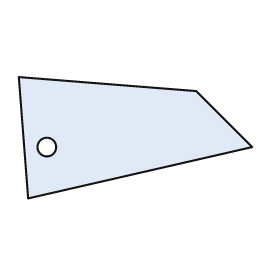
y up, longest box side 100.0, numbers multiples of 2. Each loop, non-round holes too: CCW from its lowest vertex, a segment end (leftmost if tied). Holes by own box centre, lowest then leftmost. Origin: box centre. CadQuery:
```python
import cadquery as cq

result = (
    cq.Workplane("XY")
    .moveTo(-46.0, -26.0)
    .lineTo(50.0, -4.0)
    .lineTo(26.0, 20.0)
    .lineTo(-50.0, 26.0)
    .close()
    .moveTo(-38.0, -4.0)
    .circle(4.0)
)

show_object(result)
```